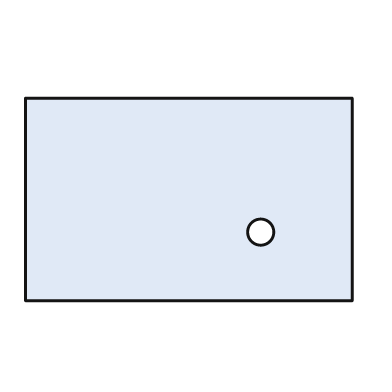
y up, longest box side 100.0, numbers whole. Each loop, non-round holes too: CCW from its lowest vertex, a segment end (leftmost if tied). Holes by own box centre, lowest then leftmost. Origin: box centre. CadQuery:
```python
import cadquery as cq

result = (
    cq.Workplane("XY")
    .moveTo(-50.0, -31.0)
    .lineTo(50.0, -31.0)
    .lineTo(50.0, 31.0)
    .lineTo(-50.0, 31.0)
    .close()
    .moveTo(22.0, -10.0)
    .circle(4.0)
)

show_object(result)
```